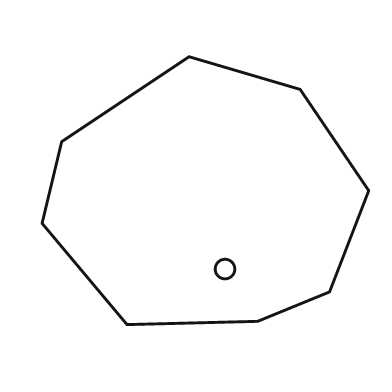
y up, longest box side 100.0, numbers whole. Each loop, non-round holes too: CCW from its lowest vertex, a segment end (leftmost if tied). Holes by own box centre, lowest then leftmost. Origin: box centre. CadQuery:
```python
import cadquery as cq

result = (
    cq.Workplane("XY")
    .moveTo(-24.0, -41.0)
    .lineTo(16.0, -40.0)
    .lineTo(38.0, -31.0)
    .lineTo(50.0, 0.0)
    .lineTo(29.0, 31.0)
    .lineTo(-5.0, 41.0)
    .lineTo(-44.0, 15.0)
    .lineTo(-50.0, -10.0)
    .close()
    .moveTo(6.0, -24.0)
    .circle(3.0)
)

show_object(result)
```